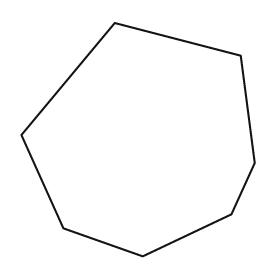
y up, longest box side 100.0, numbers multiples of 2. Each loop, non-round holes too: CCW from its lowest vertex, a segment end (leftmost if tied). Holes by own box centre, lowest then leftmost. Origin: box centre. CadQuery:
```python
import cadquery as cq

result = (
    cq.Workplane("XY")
    .moveTo(2.0, -50.0)
    .lineTo(40.0, -32.0)
    .lineTo(50.0, -10.0)
    .lineTo(44.0, 36.0)
    .lineTo(-10.0, 50.0)
    .lineTo(-50.0, 2.0)
    .lineTo(-32.0, -38.0)
    .close()
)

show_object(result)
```